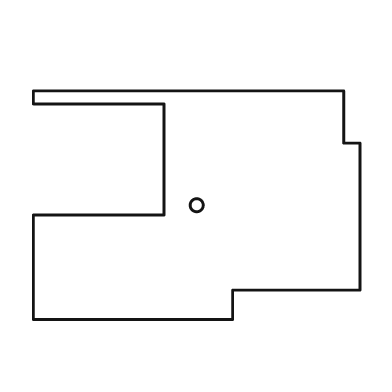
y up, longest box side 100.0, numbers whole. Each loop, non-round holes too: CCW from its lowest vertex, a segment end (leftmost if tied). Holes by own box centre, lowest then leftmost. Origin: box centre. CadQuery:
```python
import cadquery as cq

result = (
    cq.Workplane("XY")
    .moveTo(-50.0, -35.0)
    .lineTo(11.0, -35.0)
    .lineTo(11.0, -26.0)
    .lineTo(50.0, -26.0)
    .lineTo(50.0, 19.0)
    .lineTo(45.0, 19.0)
    .lineTo(45.0, 35.0)
    .lineTo(-50.0, 35.0)
    .lineTo(-50.0, 31.0)
    .lineTo(-10.0, 31.0)
    .lineTo(-10.0, -3.0)
    .lineTo(-50.0, -3.0)
    .close()
    .moveTo(0.0, 0.0)
    .circle(2.0)
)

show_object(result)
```